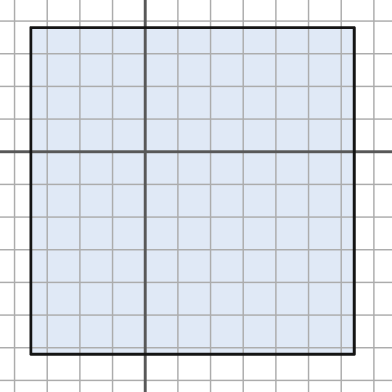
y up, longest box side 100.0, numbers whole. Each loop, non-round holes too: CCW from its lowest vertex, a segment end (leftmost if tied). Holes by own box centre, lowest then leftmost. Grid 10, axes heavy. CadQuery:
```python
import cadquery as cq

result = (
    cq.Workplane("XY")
    .moveTo(-35.0, -62.0)
    .lineTo(64.0, -62.0)
    .lineTo(64.0, 38.0)
    .lineTo(-35.0, 38.0)
    .close()
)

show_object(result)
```